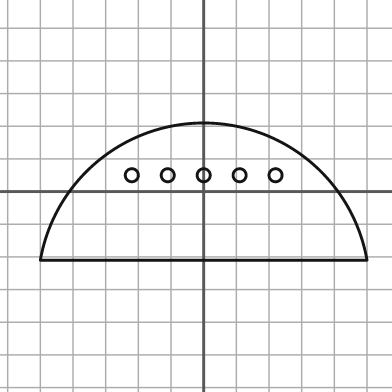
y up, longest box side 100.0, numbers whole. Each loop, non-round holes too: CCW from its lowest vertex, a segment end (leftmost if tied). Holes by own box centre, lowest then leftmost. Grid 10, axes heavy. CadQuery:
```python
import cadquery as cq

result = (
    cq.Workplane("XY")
    .moveTo(-50.0, -21.0)
    .lineTo(50.0, -21.0)
    .threePointArc((0.0, 21.0), (-50.0, -21.0))
    .close()
    .moveTo(-22.0, 5.0)
    .circle(2.0)
    .moveTo(-11.0, 5.0)
    .circle(2.0)
    .moveTo(0.0, 5.0)
    .circle(2.0)
    .moveTo(11.0, 5.0)
    .circle(2.0)
    .moveTo(22.0, 5.0)
    .circle(2.0)
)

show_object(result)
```